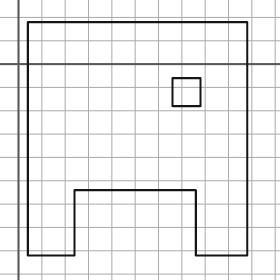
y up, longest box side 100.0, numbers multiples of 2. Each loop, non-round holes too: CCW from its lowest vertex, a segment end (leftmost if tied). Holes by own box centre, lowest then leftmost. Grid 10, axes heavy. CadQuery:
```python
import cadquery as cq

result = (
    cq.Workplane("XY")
    .moveTo(4.0, -82.0)
    .lineTo(24.0, -82.0)
    .lineTo(24.0, -54.0)
    .lineTo(76.0, -54.0)
    .lineTo(76.0, -82.0)
    .lineTo(98.0, -82.0)
    .lineTo(98.0, 18.0)
    .lineTo(4.0, 18.0)
    .close()
    .moveTo(66.0, -18.0)
    .lineTo(78.0, -18.0)
    .lineTo(78.0, -6.0)
    .lineTo(66.0, -6.0)
    .close()
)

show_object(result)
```